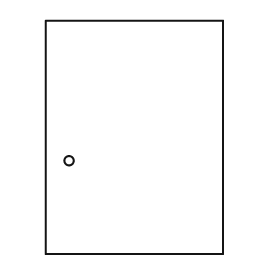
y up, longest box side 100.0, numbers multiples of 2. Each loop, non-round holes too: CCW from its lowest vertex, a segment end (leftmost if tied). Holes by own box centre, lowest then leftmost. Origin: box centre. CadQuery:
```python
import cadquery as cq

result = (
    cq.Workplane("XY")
    .moveTo(-38.0, -50.0)
    .lineTo(38.0, -50.0)
    .lineTo(38.0, 50.0)
    .lineTo(-38.0, 50.0)
    .close()
    .moveTo(-28.0, -10.0)
    .circle(2.0)
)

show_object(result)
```